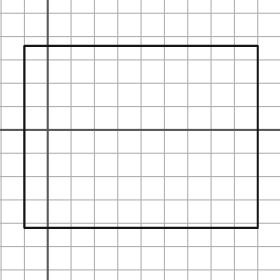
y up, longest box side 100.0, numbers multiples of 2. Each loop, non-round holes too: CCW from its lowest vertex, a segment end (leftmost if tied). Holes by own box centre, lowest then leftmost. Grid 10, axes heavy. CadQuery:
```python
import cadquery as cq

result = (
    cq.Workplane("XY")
    .moveTo(-10.0, -42.0)
    .lineTo(90.0, -42.0)
    .lineTo(90.0, 36.0)
    .lineTo(-10.0, 36.0)
    .close()
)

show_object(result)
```